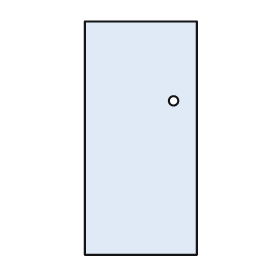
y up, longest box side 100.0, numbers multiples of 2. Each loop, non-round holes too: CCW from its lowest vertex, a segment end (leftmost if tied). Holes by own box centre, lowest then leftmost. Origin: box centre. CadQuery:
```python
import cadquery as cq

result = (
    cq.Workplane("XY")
    .moveTo(-24.0, -50.0)
    .lineTo(24.0, -50.0)
    .lineTo(24.0, 50.0)
    .lineTo(-24.0, 50.0)
    .close()
    .moveTo(14.0, 16.0)
    .circle(2.0)
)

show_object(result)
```